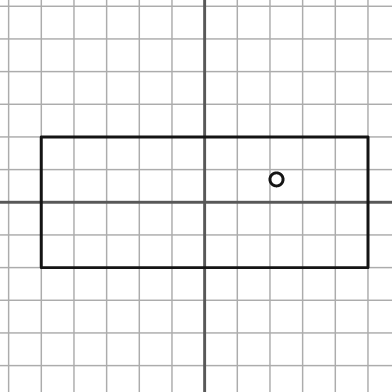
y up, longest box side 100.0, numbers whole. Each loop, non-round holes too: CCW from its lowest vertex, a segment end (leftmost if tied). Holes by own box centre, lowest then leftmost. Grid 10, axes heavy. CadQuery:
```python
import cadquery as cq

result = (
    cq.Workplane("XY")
    .moveTo(-50.0, -20.0)
    .lineTo(50.0, -20.0)
    .lineTo(50.0, 20.0)
    .lineTo(-50.0, 20.0)
    .close()
    .moveTo(22.0, 7.0)
    .circle(2.0)
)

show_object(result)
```